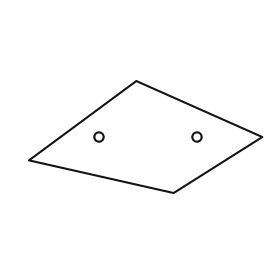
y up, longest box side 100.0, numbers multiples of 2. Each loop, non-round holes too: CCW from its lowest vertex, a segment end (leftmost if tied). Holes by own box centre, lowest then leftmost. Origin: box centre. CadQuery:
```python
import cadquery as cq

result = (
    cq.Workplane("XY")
    .moveTo(12.0, -24.0)
    .lineTo(50.0, 0.0)
    .lineTo(-4.0, 24.0)
    .lineTo(-50.0, -10.0)
    .close()
    .moveTo(-20.0, 0.0)
    .circle(2.0)
    .moveTo(22.0, 0.0)
    .circle(2.0)
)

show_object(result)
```